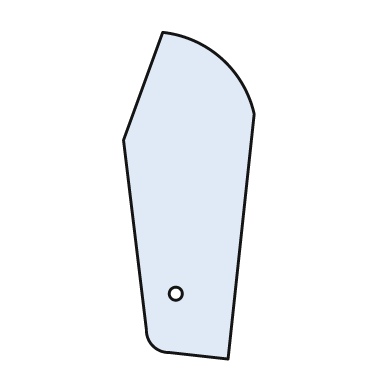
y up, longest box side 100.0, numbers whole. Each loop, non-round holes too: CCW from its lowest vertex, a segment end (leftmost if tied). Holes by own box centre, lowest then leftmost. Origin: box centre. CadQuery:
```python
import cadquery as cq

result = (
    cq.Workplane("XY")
    .moveTo(12.0, -50.0)
    .lineTo(20.0, 25.0)
    .threePointArc((10.0, 42.0), (-8.0, 50.0))
    .lineTo(-20.0, 17.0)
    .lineTo(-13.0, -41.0)
    .threePointArc((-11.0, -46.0), (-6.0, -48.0))
    .close()
    .moveTo(-4.0, -30.0)
    .circle(2.0)
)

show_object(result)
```